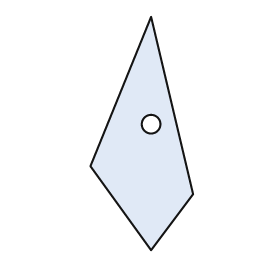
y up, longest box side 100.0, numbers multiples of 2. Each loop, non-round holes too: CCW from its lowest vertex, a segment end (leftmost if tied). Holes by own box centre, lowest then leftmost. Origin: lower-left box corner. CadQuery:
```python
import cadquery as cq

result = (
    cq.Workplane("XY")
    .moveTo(26.0, 0.0)
    .lineTo(44.0, 24.0)
    .lineTo(26.0, 100.0)
    .lineTo(0.0, 36.0)
    .close()
    .moveTo(26.0, 54.0)
    .circle(4.0)
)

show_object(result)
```